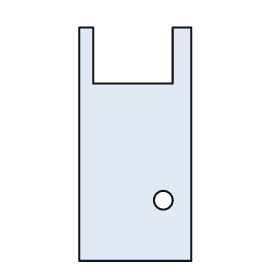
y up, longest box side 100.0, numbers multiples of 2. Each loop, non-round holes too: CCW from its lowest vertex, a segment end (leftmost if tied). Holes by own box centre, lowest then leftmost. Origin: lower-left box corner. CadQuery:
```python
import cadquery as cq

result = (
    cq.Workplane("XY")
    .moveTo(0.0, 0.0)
    .lineTo(48.0, 0.0)
    .lineTo(48.0, 100.0)
    .lineTo(40.0, 100.0)
    .lineTo(40.0, 76.0)
    .lineTo(6.0, 76.0)
    .lineTo(6.0, 100.0)
    .lineTo(0.0, 100.0)
    .close()
    .moveTo(36.0, 26.0)
    .circle(4.0)
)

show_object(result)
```